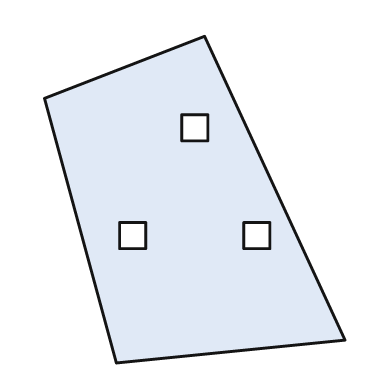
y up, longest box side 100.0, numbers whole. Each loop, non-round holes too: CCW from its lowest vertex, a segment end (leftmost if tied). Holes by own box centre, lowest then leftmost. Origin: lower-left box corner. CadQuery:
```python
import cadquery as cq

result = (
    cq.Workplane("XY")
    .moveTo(22.0, 0.0)
    .lineTo(92.0, 7.0)
    .lineTo(49.0, 100.0)
    .lineTo(0.0, 81.0)
    .close()
    .moveTo(23.0, 35.0)
    .lineTo(31.0, 35.0)
    .lineTo(31.0, 43.0)
    .lineTo(23.0, 43.0)
    .close()
    .moveTo(61.0, 35.0)
    .lineTo(69.0, 35.0)
    .lineTo(69.0, 43.0)
    .lineTo(61.0, 43.0)
    .close()
    .moveTo(42.0, 68.0)
    .lineTo(50.0, 68.0)
    .lineTo(50.0, 76.0)
    .lineTo(42.0, 76.0)
    .close()
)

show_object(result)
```